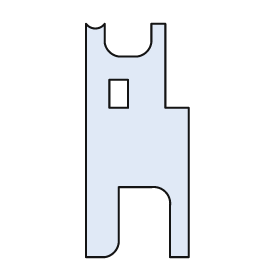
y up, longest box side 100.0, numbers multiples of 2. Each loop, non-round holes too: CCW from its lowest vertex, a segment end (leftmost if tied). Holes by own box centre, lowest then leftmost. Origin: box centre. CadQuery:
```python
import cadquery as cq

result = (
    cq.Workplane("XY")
    .moveTo(-22.0, -50.0)
    .lineTo(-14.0, -50.0)
    .threePointArc((-10.0, -48.0), (-8.0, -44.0))
    .lineTo(-8.0, -20.0)
    .lineTo(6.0, -20.0)
    .threePointArc((12.0, -22.0), (14.0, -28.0))
    .lineTo(14.0, -50.0)
    .lineTo(22.0, -50.0)
    .lineTo(22.0, 14.0)
    .lineTo(12.0, 14.0)
    .lineTo(12.0, 50.0)
    .lineTo(6.0, 50.0)
    .lineTo(6.0, 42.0)
    .threePointArc((4.0, 38.0), (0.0, 36.0))
    .lineTo(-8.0, 36.0)
    .threePointArc((-12.0, 38.0), (-14.0, 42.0))
    .lineTo(-14.0, 50.0)
    .threePointArc((-18.0, 48.0), (-22.0, 50.0))
    .close()
    .moveTo(-12.0, 14.0)
    .lineTo(-4.0, 14.0)
    .lineTo(-4.0, 26.0)
    .lineTo(-12.0, 26.0)
    .close()
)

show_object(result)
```